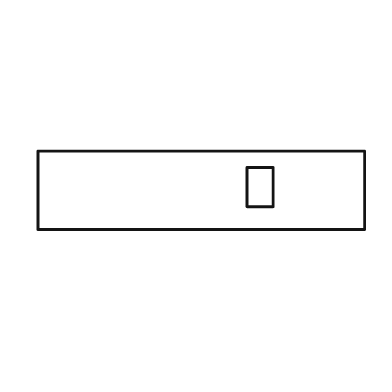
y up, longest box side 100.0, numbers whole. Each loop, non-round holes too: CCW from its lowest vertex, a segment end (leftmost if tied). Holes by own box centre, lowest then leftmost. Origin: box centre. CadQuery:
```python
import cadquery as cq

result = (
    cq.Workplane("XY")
    .moveTo(-50.0, -12.0)
    .lineTo(50.0, -12.0)
    .lineTo(50.0, 12.0)
    .lineTo(-50.0, 12.0)
    .close()
    .moveTo(14.0, -5.0)
    .lineTo(22.0, -5.0)
    .lineTo(22.0, 7.0)
    .lineTo(14.0, 7.0)
    .close()
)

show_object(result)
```